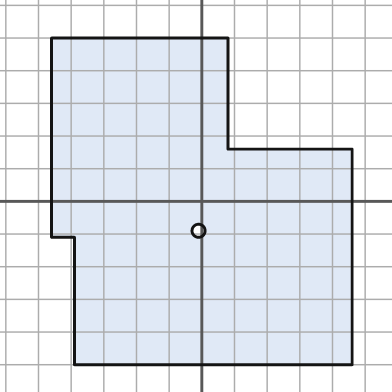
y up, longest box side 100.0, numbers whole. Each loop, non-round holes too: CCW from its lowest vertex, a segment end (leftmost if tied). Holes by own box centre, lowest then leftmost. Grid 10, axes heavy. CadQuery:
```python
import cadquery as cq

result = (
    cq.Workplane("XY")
    .moveTo(-39.0, -50.0)
    .lineTo(46.0, -50.0)
    .lineTo(46.0, 16.0)
    .lineTo(8.0, 16.0)
    .lineTo(8.0, 50.0)
    .lineTo(-46.0, 50.0)
    .lineTo(-46.0, -11.0)
    .lineTo(-39.0, -11.0)
    .close()
    .moveTo(-1.0, -9.0)
    .circle(2.0)
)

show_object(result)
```